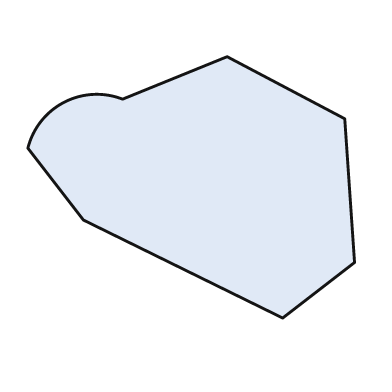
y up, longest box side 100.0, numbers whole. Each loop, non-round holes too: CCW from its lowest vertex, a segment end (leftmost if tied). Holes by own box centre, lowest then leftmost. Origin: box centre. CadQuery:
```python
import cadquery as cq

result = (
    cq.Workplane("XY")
    .moveTo(28.0, -40.0)
    .lineTo(50.0, -23.0)
    .lineTo(47.0, 21.0)
    .lineTo(11.0, 40.0)
    .lineTo(-21.0, 27.0)
    .threePointArc((-39.0, 26.0), (-50.0, 12.0))
    .lineTo(-33.0, -10.0)
    .close()
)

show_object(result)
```